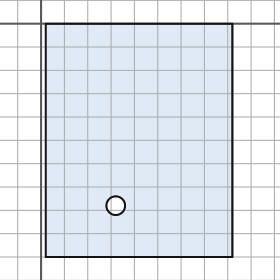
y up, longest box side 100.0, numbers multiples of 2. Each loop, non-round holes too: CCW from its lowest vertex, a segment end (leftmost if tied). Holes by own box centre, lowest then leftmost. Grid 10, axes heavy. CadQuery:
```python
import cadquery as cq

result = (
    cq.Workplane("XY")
    .moveTo(2.0, -100.0)
    .lineTo(82.0, -100.0)
    .lineTo(82.0, 0.0)
    .lineTo(2.0, 0.0)
    .close()
    .moveTo(32.0, -78.0)
    .circle(4.0)
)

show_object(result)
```